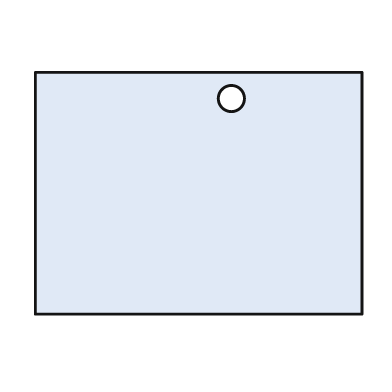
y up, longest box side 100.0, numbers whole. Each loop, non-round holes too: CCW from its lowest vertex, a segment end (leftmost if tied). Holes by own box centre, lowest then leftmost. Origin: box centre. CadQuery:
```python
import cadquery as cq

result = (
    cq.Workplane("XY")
    .moveTo(-50.0, -37.0)
    .lineTo(50.0, -37.0)
    .lineTo(50.0, 37.0)
    .lineTo(-50.0, 37.0)
    .close()
    .moveTo(10.0, 29.0)
    .circle(4.0)
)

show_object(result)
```